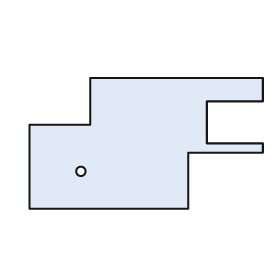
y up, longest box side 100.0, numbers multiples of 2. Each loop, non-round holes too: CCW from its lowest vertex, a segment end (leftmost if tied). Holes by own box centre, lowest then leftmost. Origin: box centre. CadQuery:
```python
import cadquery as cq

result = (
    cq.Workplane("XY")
    .moveTo(-50.0, -28.0)
    .lineTo(18.0, -28.0)
    .lineTo(18.0, -4.0)
    .lineTo(50.0, -4.0)
    .lineTo(50.0, 0.0)
    .lineTo(26.0, 0.0)
    .lineTo(26.0, 18.0)
    .lineTo(50.0, 18.0)
    .lineTo(50.0, 28.0)
    .lineTo(-24.0, 28.0)
    .lineTo(-24.0, 8.0)
    .lineTo(-50.0, 8.0)
    .close()
    .moveTo(-28.0, -12.0)
    .circle(2.0)
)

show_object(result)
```